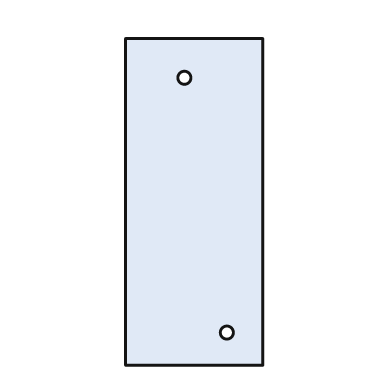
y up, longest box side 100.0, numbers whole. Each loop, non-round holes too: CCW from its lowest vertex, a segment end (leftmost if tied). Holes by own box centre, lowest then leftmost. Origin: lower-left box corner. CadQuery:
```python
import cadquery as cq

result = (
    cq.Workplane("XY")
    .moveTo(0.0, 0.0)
    .lineTo(42.0, 0.0)
    .lineTo(42.0, 100.0)
    .lineTo(0.0, 100.0)
    .close()
    .moveTo(31.0, 10.0)
    .circle(2.0)
    .moveTo(18.0, 88.0)
    .circle(2.0)
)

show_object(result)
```